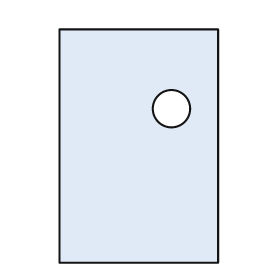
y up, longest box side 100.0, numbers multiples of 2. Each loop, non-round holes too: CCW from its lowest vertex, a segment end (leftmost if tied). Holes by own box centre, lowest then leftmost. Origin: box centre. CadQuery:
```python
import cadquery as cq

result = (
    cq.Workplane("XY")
    .moveTo(-34.0, -50.0)
    .lineTo(34.0, -50.0)
    .lineTo(34.0, 50.0)
    .lineTo(-34.0, 50.0)
    .close()
    .moveTo(14.0, 16.0)
    .circle(8.0)
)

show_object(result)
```